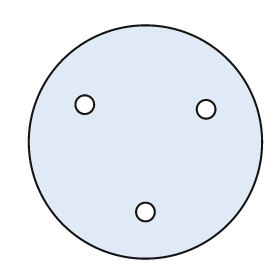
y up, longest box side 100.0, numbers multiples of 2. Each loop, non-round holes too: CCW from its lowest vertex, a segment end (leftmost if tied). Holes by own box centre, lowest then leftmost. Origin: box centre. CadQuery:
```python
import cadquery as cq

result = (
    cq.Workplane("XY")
    .moveTo(0.0, 0.0)
    .circle(50.0)
    .moveTo(0.0, -30.0)
    .circle(4.0)
    .moveTo(26.0, 14.0)
    .circle(4.0)
    .moveTo(-26.0, 16.0)
    .circle(4.0)
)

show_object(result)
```